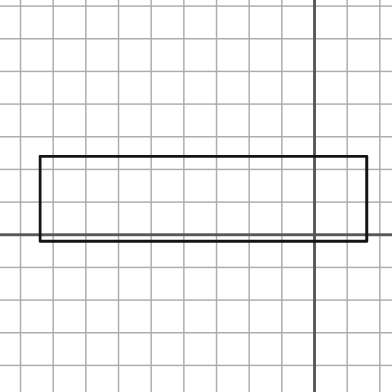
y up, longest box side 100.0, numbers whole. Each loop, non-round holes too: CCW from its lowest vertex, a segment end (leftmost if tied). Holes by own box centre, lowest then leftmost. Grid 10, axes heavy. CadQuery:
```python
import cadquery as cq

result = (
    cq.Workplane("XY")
    .moveTo(-84.0, -2.0)
    .lineTo(16.0, -2.0)
    .lineTo(16.0, 24.0)
    .lineTo(-84.0, 24.0)
    .close()
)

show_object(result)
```